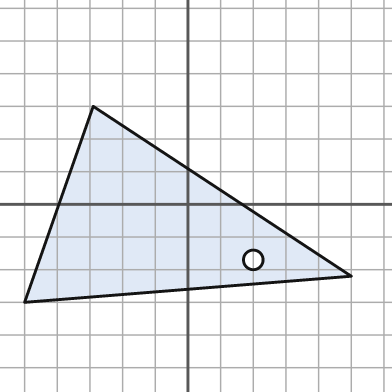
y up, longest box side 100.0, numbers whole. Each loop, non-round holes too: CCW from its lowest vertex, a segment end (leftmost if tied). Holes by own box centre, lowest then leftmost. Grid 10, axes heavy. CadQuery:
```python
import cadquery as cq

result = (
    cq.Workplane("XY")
    .moveTo(-50.0, -30.0)
    .lineTo(50.0, -22.0)
    .lineTo(-29.0, 30.0)
    .close()
    .moveTo(20.0, -17.0)
    .circle(3.0)
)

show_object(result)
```